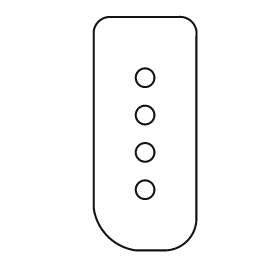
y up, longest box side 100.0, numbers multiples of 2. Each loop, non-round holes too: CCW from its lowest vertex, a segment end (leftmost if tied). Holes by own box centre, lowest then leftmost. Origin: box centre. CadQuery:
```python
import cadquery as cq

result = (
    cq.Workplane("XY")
    .moveTo(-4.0, -50.0)
    .lineTo(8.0, -50.0)
    .threePointArc((18.0, -46.0), (22.0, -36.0))
    .lineTo(22.0, 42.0)
    .threePointArc((20.0, 48.0), (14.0, 50.0))
    .lineTo(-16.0, 50.0)
    .threePointArc((-20.0, 48.0), (-22.0, 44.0))
    .lineTo(-22.0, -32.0)
    .threePointArc((-16.0, -44.0), (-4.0, -50.0))
    .close()
    .moveTo(0.0, -24.0)
    .circle(4.0)
    .moveTo(0.0, -8.0)
    .circle(4.0)
    .moveTo(0.0, 8.0)
    .circle(4.0)
    .moveTo(0.0, 24.0)
    .circle(4.0)
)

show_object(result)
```